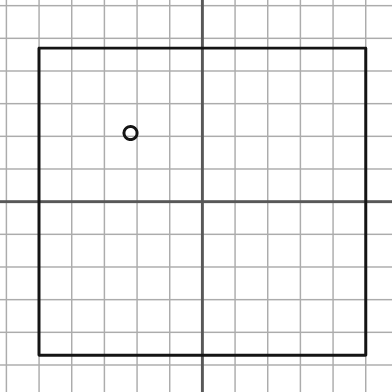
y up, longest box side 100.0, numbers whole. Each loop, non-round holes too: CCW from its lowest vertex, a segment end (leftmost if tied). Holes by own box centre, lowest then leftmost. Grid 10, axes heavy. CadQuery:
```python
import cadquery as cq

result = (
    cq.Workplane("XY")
    .moveTo(-50.0, -47.0)
    .lineTo(50.0, -47.0)
    .lineTo(50.0, 47.0)
    .lineTo(-50.0, 47.0)
    .close()
    .moveTo(-22.0, 21.0)
    .circle(2.0)
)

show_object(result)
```